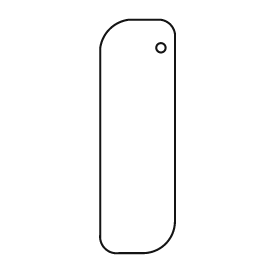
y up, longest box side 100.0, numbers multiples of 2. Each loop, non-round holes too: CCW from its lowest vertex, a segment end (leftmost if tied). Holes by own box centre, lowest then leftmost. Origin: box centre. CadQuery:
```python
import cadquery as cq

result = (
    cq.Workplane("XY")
    .moveTo(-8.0, -50.0)
    .lineTo(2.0, -50.0)
    .threePointArc((12.0, -46.0), (16.0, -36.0))
    .lineTo(16.0, 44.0)
    .threePointArc((14.0, 48.0), (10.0, 50.0))
    .lineTo(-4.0, 50.0)
    .threePointArc((-12.0, 46.0), (-16.0, 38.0))
    .lineTo(-16.0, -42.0)
    .threePointArc((-14.0, -48.0), (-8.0, -50.0))
    .close()
    .moveTo(10.0, 38.0)
    .circle(2.0)
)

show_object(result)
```